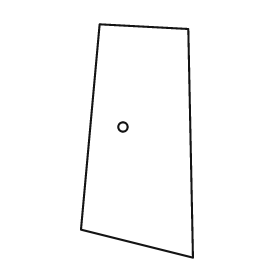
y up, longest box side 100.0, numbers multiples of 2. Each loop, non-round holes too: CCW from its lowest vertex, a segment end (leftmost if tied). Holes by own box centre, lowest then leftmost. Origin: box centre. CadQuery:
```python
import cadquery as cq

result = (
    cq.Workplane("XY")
    .moveTo(24.0, -50.0)
    .lineTo(22.0, 48.0)
    .lineTo(-16.0, 50.0)
    .lineTo(-24.0, -38.0)
    .close()
    .moveTo(-6.0, 6.0)
    .circle(2.0)
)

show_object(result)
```